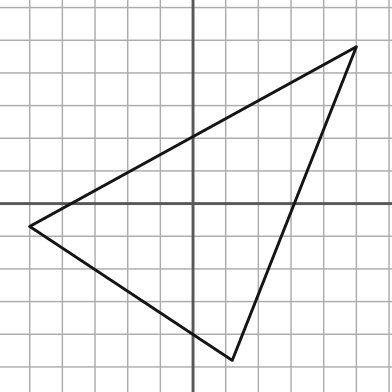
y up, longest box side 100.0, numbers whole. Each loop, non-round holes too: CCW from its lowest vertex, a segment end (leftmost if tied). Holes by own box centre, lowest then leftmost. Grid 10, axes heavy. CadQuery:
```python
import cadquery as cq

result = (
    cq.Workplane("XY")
    .moveTo(12.0, -48.0)
    .lineTo(50.0, 48.0)
    .lineTo(-50.0, -7.0)
    .close()
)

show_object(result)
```